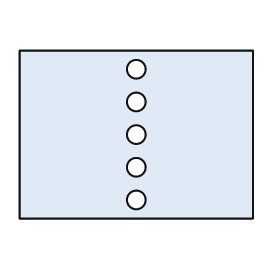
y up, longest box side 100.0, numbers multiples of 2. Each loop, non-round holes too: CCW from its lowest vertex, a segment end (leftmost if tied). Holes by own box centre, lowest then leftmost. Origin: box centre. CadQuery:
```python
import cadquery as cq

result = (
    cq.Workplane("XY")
    .moveTo(-50.0, -36.0)
    .lineTo(50.0, -36.0)
    .lineTo(50.0, 36.0)
    .lineTo(-50.0, 36.0)
    .close()
    .moveTo(0.0, -28.0)
    .circle(4.0)
    .moveTo(0.0, -14.0)
    .circle(4.0)
    .moveTo(0.0, 0.0)
    .circle(4.0)
    .moveTo(0.0, 14.0)
    .circle(4.0)
    .moveTo(0.0, 28.0)
    .circle(4.0)
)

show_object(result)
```